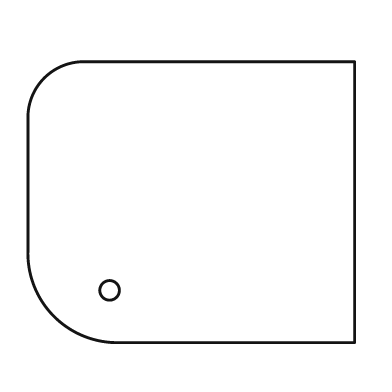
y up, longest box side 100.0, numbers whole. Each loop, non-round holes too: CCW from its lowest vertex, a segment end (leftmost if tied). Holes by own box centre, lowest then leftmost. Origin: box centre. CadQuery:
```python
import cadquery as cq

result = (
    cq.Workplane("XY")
    .moveTo(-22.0, -43.0)
    .lineTo(50.0, -43.0)
    .lineTo(50.0, 43.0)
    .lineTo(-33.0, 43.0)
    .threePointArc((-45.0, 38.0), (-50.0, 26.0))
    .lineTo(-50.0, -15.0)
    .threePointArc((-42.0, -35.0), (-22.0, -43.0))
    .close()
    .moveTo(-25.0, -27.0)
    .circle(3.0)
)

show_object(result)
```